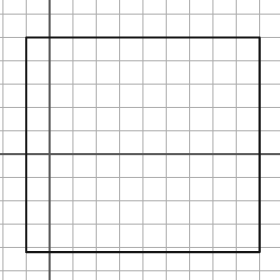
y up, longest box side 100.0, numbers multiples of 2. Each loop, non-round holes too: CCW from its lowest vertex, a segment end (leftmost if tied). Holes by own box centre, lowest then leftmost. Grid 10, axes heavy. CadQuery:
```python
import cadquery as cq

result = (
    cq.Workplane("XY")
    .moveTo(-10.0, -42.0)
    .lineTo(90.0, -42.0)
    .lineTo(90.0, 50.0)
    .lineTo(-10.0, 50.0)
    .close()
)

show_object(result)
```